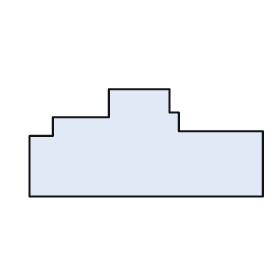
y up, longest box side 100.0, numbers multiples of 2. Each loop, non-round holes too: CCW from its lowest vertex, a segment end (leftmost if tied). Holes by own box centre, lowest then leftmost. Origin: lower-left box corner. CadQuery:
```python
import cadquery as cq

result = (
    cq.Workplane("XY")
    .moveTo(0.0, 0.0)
    .lineTo(100.0, 0.0)
    .lineTo(100.0, 28.0)
    .lineTo(64.0, 28.0)
    .lineTo(64.0, 36.0)
    .lineTo(60.0, 36.0)
    .lineTo(60.0, 46.0)
    .lineTo(34.0, 46.0)
    .lineTo(34.0, 34.0)
    .lineTo(10.0, 34.0)
    .lineTo(10.0, 26.0)
    .lineTo(0.0, 26.0)
    .close()
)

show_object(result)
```